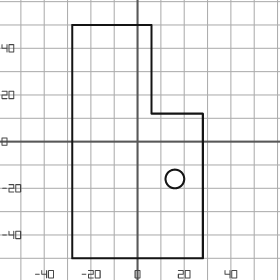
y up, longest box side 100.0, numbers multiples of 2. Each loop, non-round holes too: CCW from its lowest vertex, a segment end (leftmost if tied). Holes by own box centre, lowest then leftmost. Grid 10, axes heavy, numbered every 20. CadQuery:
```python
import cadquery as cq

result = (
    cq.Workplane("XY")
    .moveTo(-28.0, -50.0)
    .lineTo(28.0, -50.0)
    .lineTo(28.0, 12.0)
    .lineTo(6.0, 12.0)
    .lineTo(6.0, 50.0)
    .lineTo(-28.0, 50.0)
    .close()
    .moveTo(16.0, -16.0)
    .circle(4.0)
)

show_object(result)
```